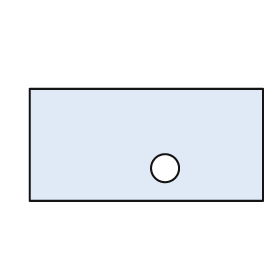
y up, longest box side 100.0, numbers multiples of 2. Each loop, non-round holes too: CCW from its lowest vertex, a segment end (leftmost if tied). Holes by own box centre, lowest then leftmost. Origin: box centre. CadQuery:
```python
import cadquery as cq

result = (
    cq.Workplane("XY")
    .moveTo(-50.0, -24.0)
    .lineTo(50.0, -24.0)
    .lineTo(50.0, 24.0)
    .lineTo(-50.0, 24.0)
    .close()
    .moveTo(8.0, -10.0)
    .circle(6.0)
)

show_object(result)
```